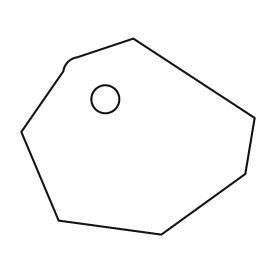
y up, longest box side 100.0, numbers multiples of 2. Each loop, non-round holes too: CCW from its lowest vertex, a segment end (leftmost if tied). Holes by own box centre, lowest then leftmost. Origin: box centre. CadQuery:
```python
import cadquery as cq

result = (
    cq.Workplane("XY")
    .moveTo(10.0, -42.0)
    .lineTo(46.0, -16.0)
    .lineTo(50.0, 8.0)
    .lineTo(-2.0, 42.0)
    .lineTo(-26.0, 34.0)
    .threePointArc((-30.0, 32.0), (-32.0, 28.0))
    .lineTo(-50.0, 2.0)
    .lineTo(-34.0, -36.0)
    .close()
    .moveTo(-14.0, 16.0)
    .circle(6.0)
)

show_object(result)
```